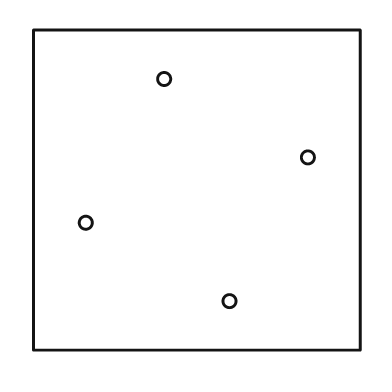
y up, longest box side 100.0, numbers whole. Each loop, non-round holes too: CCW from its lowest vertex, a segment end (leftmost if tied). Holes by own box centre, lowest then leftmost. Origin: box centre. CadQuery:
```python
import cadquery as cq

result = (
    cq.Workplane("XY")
    .moveTo(-50.0, -49.0)
    .lineTo(50.0, -49.0)
    .lineTo(50.0, 49.0)
    .lineTo(-50.0, 49.0)
    .close()
    .moveTo(10.0, -34.0)
    .circle(2.0)
    .moveTo(-34.0, -10.0)
    .circle(2.0)
    .moveTo(34.0, 10.0)
    .circle(2.0)
    .moveTo(-10.0, 34.0)
    .circle(2.0)
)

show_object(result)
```